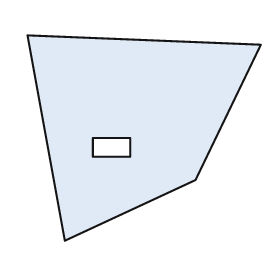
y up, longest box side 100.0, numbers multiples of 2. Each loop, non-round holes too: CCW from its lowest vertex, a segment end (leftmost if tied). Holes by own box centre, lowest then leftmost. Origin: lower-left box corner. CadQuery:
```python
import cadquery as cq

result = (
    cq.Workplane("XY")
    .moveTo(16.0, 0.0)
    .lineTo(72.0, 26.0)
    .lineTo(100.0, 84.0)
    .lineTo(0.0, 88.0)
    .close()
    .moveTo(28.0, 36.0)
    .lineTo(44.0, 36.0)
    .lineTo(44.0, 44.0)
    .lineTo(28.0, 44.0)
    .close()
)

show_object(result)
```